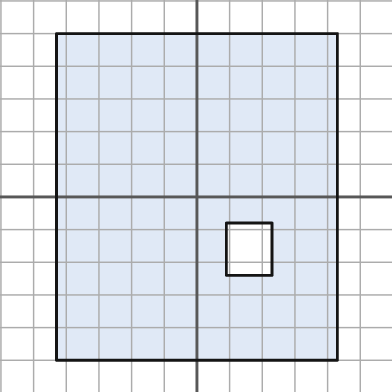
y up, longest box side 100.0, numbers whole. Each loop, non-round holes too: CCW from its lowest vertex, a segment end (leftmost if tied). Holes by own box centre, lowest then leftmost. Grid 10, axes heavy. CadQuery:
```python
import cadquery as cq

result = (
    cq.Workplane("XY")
    .moveTo(-43.0, -50.0)
    .lineTo(43.0, -50.0)
    .lineTo(43.0, 50.0)
    .lineTo(-43.0, 50.0)
    .close()
    .moveTo(9.0, -24.0)
    .lineTo(23.0, -24.0)
    .lineTo(23.0, -8.0)
    .lineTo(9.0, -8.0)
    .close()
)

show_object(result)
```